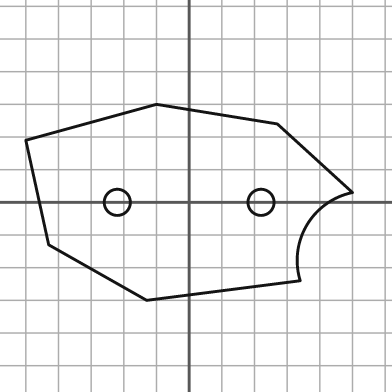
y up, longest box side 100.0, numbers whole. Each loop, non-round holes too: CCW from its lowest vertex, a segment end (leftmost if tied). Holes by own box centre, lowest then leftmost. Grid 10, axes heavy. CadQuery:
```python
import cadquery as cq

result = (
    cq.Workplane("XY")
    .moveTo(-13.0, -30.0)
    .lineTo(34.0, -24.0)
    .threePointArc((36.0, -7.0), (50.0, 3.0))
    .lineTo(27.0, 24.0)
    .lineTo(-10.0, 30.0)
    .lineTo(-50.0, 19.0)
    .lineTo(-43.0, -13.0)
    .close()
    .moveTo(-22.0, 0.0)
    .circle(4.0)
    .moveTo(22.0, 0.0)
    .circle(4.0)
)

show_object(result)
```